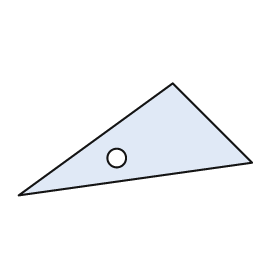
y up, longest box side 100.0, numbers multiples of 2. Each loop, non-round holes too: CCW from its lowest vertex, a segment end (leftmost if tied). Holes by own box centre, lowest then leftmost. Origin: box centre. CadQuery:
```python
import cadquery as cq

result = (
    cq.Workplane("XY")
    .moveTo(-50.0, -24.0)
    .lineTo(50.0, -10.0)
    .lineTo(16.0, 24.0)
    .close()
    .moveTo(-8.0, -8.0)
    .circle(4.0)
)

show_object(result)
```